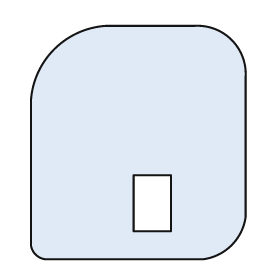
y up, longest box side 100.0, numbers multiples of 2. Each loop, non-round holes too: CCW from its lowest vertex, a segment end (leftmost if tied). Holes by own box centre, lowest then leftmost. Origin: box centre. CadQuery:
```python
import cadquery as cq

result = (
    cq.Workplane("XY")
    .moveTo(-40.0, -50.0)
    .lineTo(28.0, -50.0)
    .threePointArc((40.0, -44.0), (46.0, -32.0))
    .lineTo(46.0, 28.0)
    .threePointArc((40.0, 44.0), (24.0, 50.0))
    .lineTo(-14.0, 50.0)
    .threePointArc((-36.0, 40.0), (-46.0, 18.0))
    .lineTo(-46.0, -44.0)
    .threePointArc((-44.0, -48.0), (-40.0, -50.0))
    .close()
    .moveTo(-2.0, -38.0)
    .lineTo(14.0, -38.0)
    .lineTo(14.0, -14.0)
    .lineTo(-2.0, -14.0)
    .close()
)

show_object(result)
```